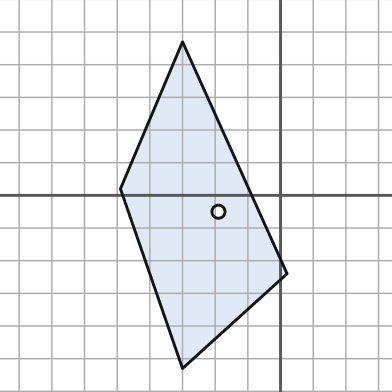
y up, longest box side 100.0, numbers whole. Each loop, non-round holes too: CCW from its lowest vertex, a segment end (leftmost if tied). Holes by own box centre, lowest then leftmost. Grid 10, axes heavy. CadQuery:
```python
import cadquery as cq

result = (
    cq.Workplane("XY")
    .moveTo(-30.0, -53.0)
    .lineTo(2.0, -24.0)
    .lineTo(-30.0, 47.0)
    .lineTo(-49.0, 2.0)
    .close()
    .moveTo(-19.0, -5.0)
    .circle(2.0)
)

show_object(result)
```